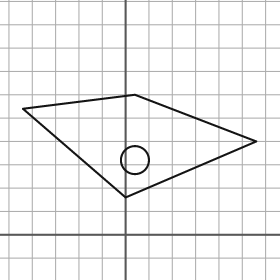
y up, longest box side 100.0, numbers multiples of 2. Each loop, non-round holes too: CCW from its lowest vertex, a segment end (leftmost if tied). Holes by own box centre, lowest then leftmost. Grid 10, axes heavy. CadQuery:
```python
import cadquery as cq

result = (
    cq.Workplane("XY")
    .moveTo(0.0, 16.0)
    .lineTo(56.0, 40.0)
    .lineTo(4.0, 60.0)
    .lineTo(-44.0, 54.0)
    .close()
    .moveTo(4.0, 32.0)
    .circle(6.0)
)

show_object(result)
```